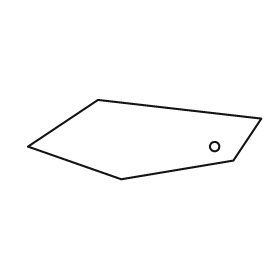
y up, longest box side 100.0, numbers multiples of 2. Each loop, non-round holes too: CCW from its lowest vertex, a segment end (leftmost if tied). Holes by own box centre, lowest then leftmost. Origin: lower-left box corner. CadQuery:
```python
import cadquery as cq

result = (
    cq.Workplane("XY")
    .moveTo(40.0, 0.0)
    .lineTo(88.0, 8.0)
    .lineTo(100.0, 26.0)
    .lineTo(30.0, 34.0)
    .lineTo(0.0, 14.0)
    .close()
    .moveTo(80.0, 14.0)
    .circle(2.0)
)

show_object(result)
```